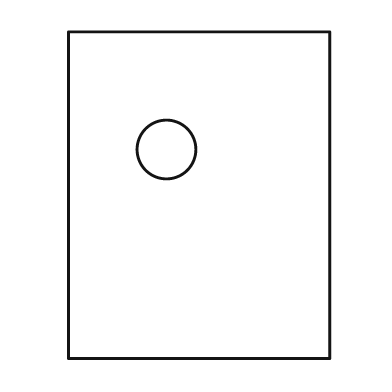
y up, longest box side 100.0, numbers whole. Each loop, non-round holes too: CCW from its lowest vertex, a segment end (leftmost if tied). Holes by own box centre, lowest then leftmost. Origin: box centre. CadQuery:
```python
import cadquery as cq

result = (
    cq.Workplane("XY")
    .moveTo(-40.0, -50.0)
    .lineTo(40.0, -50.0)
    .lineTo(40.0, 50.0)
    .lineTo(-40.0, 50.0)
    .close()
    .moveTo(-10.0, 14.0)
    .circle(9.0)
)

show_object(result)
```